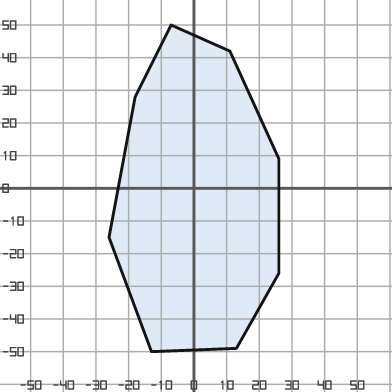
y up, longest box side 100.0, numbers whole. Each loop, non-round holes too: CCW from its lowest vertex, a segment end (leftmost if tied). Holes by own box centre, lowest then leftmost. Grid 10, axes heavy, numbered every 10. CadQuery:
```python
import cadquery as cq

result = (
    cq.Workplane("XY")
    .moveTo(-13.0, -50.0)
    .lineTo(13.0, -49.0)
    .lineTo(26.0, -26.0)
    .lineTo(26.0, 9.0)
    .lineTo(11.0, 42.0)
    .lineTo(-7.0, 50.0)
    .lineTo(-18.0, 28.0)
    .lineTo(-26.0, -15.0)
    .close()
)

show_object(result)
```